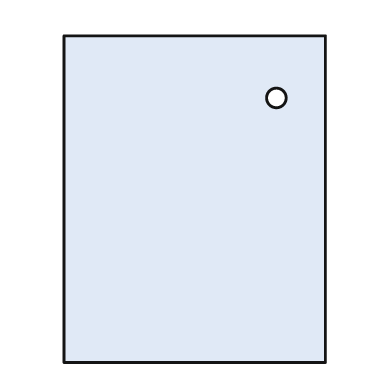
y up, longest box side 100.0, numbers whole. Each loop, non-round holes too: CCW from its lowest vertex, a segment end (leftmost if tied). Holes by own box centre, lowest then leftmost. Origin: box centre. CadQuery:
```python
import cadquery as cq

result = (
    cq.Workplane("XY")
    .moveTo(-40.0, -50.0)
    .lineTo(40.0, -50.0)
    .lineTo(40.0, 50.0)
    .lineTo(-40.0, 50.0)
    .close()
    .moveTo(25.0, 31.0)
    .circle(3.0)
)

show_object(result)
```